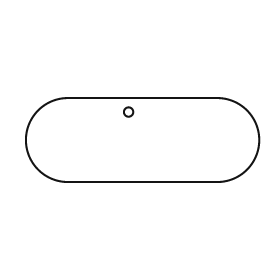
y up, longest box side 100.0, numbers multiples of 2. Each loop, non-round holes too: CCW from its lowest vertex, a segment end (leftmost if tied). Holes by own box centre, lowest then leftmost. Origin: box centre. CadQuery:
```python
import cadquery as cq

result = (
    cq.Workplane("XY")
    .moveTo(-32.0, -18.0)
    .lineTo(32.0, -18.0)
    .threePointArc((50.0, 0.0), (32.0, 18.0))
    .lineTo(-32.0, 18.0)
    .threePointArc((-50.0, 0.0), (-32.0, -18.0))
    .close()
    .moveTo(-6.0, 12.0)
    .circle(2.0)
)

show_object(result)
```